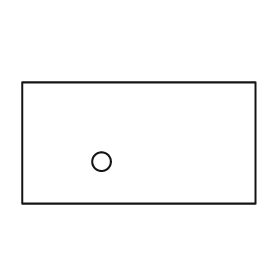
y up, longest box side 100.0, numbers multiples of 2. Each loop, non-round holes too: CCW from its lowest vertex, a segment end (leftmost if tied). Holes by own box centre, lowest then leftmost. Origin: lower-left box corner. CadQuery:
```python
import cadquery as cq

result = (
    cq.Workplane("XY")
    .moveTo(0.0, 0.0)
    .lineTo(100.0, 0.0)
    .lineTo(100.0, 52.0)
    .lineTo(0.0, 52.0)
    .close()
    .moveTo(34.0, 18.0)
    .circle(4.0)
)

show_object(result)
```